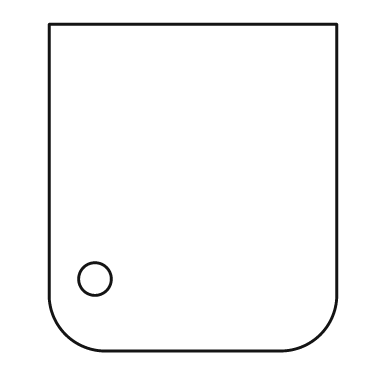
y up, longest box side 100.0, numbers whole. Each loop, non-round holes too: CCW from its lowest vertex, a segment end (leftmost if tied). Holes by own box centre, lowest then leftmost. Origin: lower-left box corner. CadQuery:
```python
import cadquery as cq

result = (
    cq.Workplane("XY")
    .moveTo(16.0, 0.0)
    .lineTo(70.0, 0.0)
    .threePointArc((83.0, 5.0), (88.0, 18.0))
    .lineTo(88.0, 100.0)
    .lineTo(0.0, 100.0)
    .lineTo(0.0, 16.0)
    .threePointArc((5.0, 5.0), (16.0, 0.0))
    .close()
    .moveTo(14.0, 22.0)
    .circle(5.0)
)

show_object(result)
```